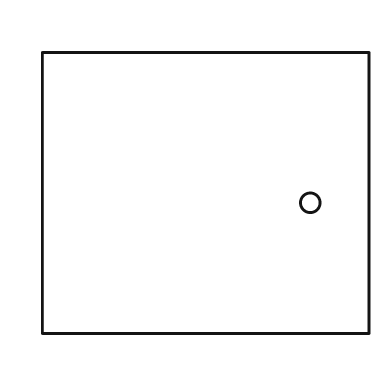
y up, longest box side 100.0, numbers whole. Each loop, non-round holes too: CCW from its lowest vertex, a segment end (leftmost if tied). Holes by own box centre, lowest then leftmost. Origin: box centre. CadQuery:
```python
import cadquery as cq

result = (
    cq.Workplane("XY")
    .moveTo(-50.0, -43.0)
    .lineTo(50.0, -43.0)
    .lineTo(50.0, 43.0)
    .lineTo(-50.0, 43.0)
    .close()
    .moveTo(32.0, -3.0)
    .circle(3.0)
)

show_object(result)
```